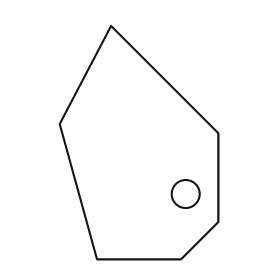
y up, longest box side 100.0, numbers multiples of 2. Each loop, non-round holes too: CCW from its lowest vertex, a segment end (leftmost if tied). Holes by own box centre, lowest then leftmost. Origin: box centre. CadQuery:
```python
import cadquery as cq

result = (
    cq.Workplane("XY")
    .moveTo(-18.0, -50.0)
    .lineTo(18.0, -50.0)
    .lineTo(34.0, -34.0)
    .lineTo(34.0, 4.0)
    .lineTo(-12.0, 50.0)
    .lineTo(-34.0, 8.0)
    .close()
    .moveTo(20.0, -22.0)
    .circle(6.0)
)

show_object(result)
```